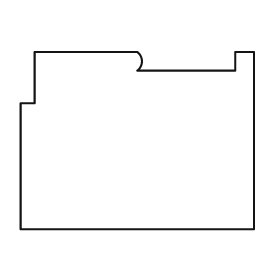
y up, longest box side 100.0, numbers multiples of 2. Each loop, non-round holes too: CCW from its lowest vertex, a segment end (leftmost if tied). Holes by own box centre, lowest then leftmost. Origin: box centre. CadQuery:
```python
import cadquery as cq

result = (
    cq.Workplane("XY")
    .moveTo(-50.0, -38.0)
    .lineTo(50.0, -38.0)
    .lineTo(50.0, 38.0)
    .lineTo(42.0, 38.0)
    .lineTo(42.0, 30.0)
    .lineTo(0.0, 30.0)
    .threePointArc((2.0, 34.0), (0.0, 38.0))
    .lineTo(-44.0, 38.0)
    .lineTo(-44.0, 16.0)
    .lineTo(-50.0, 16.0)
    .close()
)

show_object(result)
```